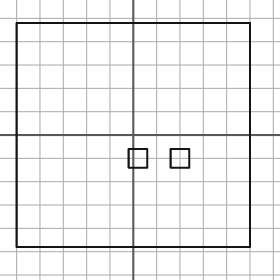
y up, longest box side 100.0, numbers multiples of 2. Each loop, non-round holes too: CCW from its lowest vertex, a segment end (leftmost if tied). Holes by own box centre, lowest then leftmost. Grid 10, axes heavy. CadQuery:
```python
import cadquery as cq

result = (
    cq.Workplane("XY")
    .moveTo(-50.0, -48.0)
    .lineTo(50.0, -48.0)
    .lineTo(50.0, 48.0)
    .lineTo(-50.0, 48.0)
    .close()
    .moveTo(-2.0, -14.0)
    .lineTo(6.0, -14.0)
    .lineTo(6.0, -6.0)
    .lineTo(-2.0, -6.0)
    .close()
    .moveTo(16.0, -14.0)
    .lineTo(24.0, -14.0)
    .lineTo(24.0, -6.0)
    .lineTo(16.0, -6.0)
    .close()
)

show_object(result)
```